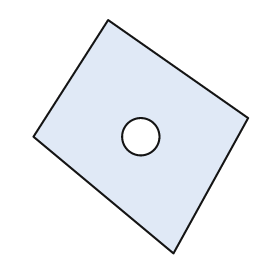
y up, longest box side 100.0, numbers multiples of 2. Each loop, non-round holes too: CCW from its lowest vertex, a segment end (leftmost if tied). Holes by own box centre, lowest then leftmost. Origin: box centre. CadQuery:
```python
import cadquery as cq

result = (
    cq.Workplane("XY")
    .moveTo(14.0, -50.0)
    .lineTo(46.0, 8.0)
    .lineTo(-14.0, 50.0)
    .lineTo(-46.0, 0.0)
    .close()
    .moveTo(0.0, 0.0)
    .circle(8.0)
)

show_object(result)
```